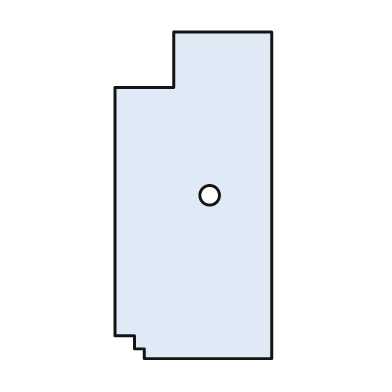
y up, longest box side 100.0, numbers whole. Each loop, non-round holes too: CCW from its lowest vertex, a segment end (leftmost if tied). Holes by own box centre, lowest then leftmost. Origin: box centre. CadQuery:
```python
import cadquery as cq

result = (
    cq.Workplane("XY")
    .moveTo(-15.0, -50.0)
    .lineTo(24.0, -50.0)
    .lineTo(24.0, 50.0)
    .lineTo(-6.0, 50.0)
    .lineTo(-6.0, 33.0)
    .lineTo(-24.0, 33.0)
    .lineTo(-24.0, -43.0)
    .lineTo(-18.0, -43.0)
    .lineTo(-18.0, -47.0)
    .lineTo(-15.0, -47.0)
    .close()
    .moveTo(5.0, 0.0)
    .circle(3.0)
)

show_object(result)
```